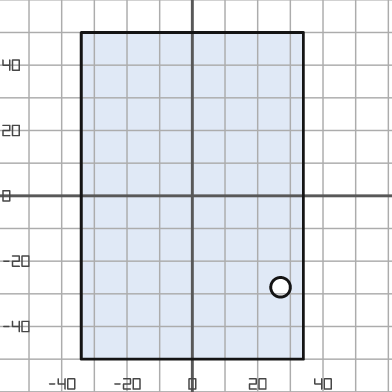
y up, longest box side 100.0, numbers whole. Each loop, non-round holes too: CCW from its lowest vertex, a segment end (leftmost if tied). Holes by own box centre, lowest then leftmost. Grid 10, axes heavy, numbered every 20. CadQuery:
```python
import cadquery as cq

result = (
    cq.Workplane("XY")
    .moveTo(-34.0, -50.0)
    .lineTo(34.0, -50.0)
    .lineTo(34.0, 50.0)
    .lineTo(-34.0, 50.0)
    .close()
    .moveTo(27.0, -28.0)
    .circle(3.0)
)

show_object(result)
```